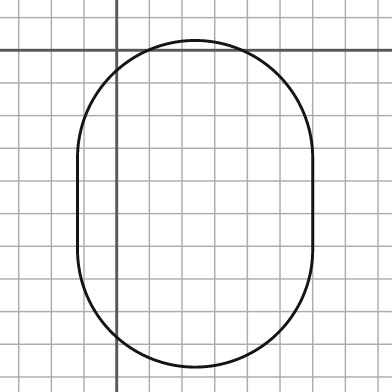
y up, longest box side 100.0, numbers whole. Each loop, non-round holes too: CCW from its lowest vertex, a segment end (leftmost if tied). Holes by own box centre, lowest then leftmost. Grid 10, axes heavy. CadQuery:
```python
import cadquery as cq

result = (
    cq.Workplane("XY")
    .moveTo(-12.0, -61.0)
    .threePointArc((24.0, -97.0), (60.0, -61.0))
    .lineTo(60.0, -33.0)
    .threePointArc((24.0, 3.0), (-12.0, -33.0))
    .close()
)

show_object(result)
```